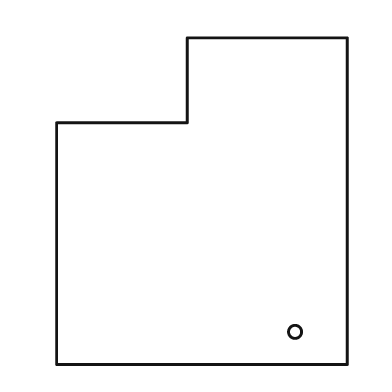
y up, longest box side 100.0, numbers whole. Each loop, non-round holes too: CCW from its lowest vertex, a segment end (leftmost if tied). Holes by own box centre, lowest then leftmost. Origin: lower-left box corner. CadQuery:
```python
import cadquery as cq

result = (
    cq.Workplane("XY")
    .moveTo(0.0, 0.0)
    .lineTo(89.0, 0.0)
    .lineTo(89.0, 100.0)
    .lineTo(40.0, 100.0)
    .lineTo(40.0, 74.0)
    .lineTo(0.0, 74.0)
    .close()
    .moveTo(73.0, 10.0)
    .circle(2.0)
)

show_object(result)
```